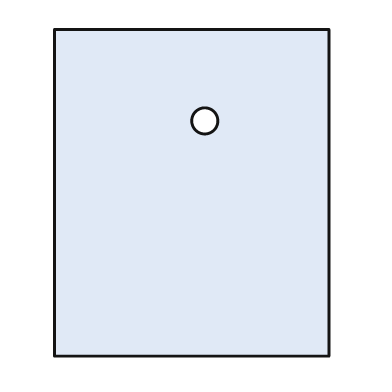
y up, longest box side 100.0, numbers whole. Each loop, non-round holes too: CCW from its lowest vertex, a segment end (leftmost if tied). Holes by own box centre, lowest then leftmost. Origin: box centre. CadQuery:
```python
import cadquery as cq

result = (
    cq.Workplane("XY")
    .moveTo(-42.0, -50.0)
    .lineTo(42.0, -50.0)
    .lineTo(42.0, 50.0)
    .lineTo(-42.0, 50.0)
    .close()
    .moveTo(4.0, 22.0)
    .circle(4.0)
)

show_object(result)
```